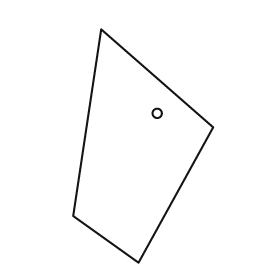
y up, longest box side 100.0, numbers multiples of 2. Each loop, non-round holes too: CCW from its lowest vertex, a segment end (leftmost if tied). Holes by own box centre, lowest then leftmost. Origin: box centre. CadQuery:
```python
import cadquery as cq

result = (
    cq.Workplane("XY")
    .moveTo(-2.0, -50.0)
    .lineTo(30.0, 8.0)
    .lineTo(-18.0, 50.0)
    .lineTo(-30.0, -30.0)
    .close()
    .moveTo(6.0, 14.0)
    .circle(2.0)
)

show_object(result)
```